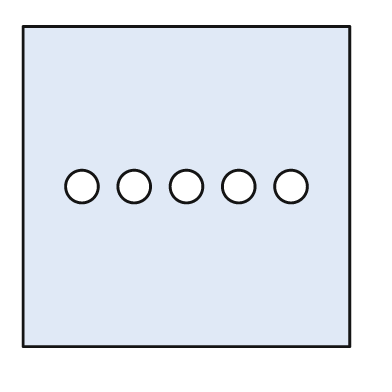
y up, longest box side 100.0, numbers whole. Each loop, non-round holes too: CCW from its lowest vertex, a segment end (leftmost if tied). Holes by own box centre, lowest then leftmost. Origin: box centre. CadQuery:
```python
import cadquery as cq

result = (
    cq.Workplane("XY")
    .moveTo(-50.0, -49.0)
    .lineTo(50.0, -49.0)
    .lineTo(50.0, 49.0)
    .lineTo(-50.0, 49.0)
    .close()
    .moveTo(-32.0, 0.0)
    .circle(5.0)
    .moveTo(-16.0, 0.0)
    .circle(5.0)
    .moveTo(0.0, 0.0)
    .circle(5.0)
    .moveTo(16.0, 0.0)
    .circle(5.0)
    .moveTo(32.0, 0.0)
    .circle(5.0)
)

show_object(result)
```